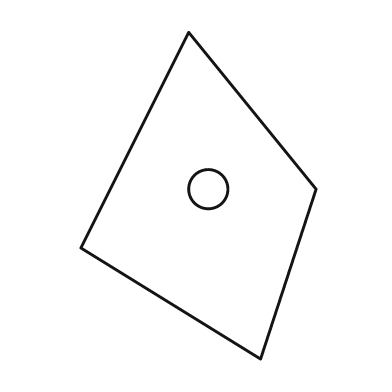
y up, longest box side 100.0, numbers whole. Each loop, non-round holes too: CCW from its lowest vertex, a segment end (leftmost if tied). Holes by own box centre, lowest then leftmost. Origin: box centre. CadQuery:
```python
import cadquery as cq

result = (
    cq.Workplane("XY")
    .moveTo(19.0, -50.0)
    .lineTo(36.0, 2.0)
    .lineTo(-3.0, 50.0)
    .lineTo(-36.0, -16.0)
    .close()
    .moveTo(3.0, 2.0)
    .circle(6.0)
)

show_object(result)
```